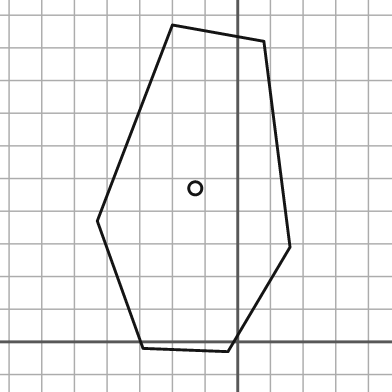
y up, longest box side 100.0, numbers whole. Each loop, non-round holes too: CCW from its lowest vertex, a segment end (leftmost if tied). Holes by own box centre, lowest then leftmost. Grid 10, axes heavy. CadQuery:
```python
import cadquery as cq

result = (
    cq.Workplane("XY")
    .moveTo(-3.0, -3.0)
    .lineTo(16.0, 29.0)
    .lineTo(8.0, 92.0)
    .lineTo(-20.0, 97.0)
    .lineTo(-43.0, 37.0)
    .lineTo(-29.0, -2.0)
    .close()
    .moveTo(-13.0, 47.0)
    .circle(2.0)
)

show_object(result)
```